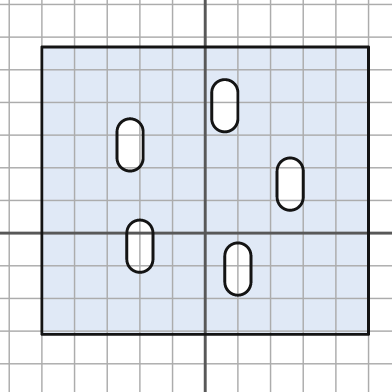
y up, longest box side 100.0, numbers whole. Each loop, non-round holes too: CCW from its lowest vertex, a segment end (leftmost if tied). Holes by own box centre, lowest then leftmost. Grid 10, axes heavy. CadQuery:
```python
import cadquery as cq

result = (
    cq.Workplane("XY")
    .moveTo(-50.0, -31.0)
    .lineTo(50.0, -31.0)
    .lineTo(50.0, 57.0)
    .lineTo(-50.0, 57.0)
    .close()
    .moveTo(6.0, -15.0)
    .threePointArc((10.0, -19.0), (14.0, -15.0))
    .lineTo(14.0, -7.0)
    .threePointArc((10.0, -3.0), (6.0, -7.0))
    .close()
    .moveTo(-24.0, -8.0)
    .threePointArc((-20.0, -12.0), (-16.0, -8.0))
    .lineTo(-16.0, 0.0)
    .threePointArc((-20.0, 4.0), (-24.0, 0.0))
    .close()
    .moveTo(22.0, 11.0)
    .threePointArc((26.0, 7.0), (30.0, 11.0))
    .lineTo(30.0, 19.0)
    .threePointArc((26.0, 23.0), (22.0, 19.0))
    .close()
    .moveTo(-27.0, 23.0)
    .threePointArc((-23.0, 19.0), (-19.0, 23.0))
    .lineTo(-19.0, 31.0)
    .threePointArc((-23.0, 35.0), (-27.0, 31.0))
    .close()
    .moveTo(2.0, 35.0)
    .threePointArc((6.0, 31.0), (10.0, 35.0))
    .lineTo(10.0, 43.0)
    .threePointArc((6.0, 47.0), (2.0, 43.0))
    .close()
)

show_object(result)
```